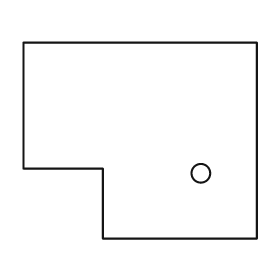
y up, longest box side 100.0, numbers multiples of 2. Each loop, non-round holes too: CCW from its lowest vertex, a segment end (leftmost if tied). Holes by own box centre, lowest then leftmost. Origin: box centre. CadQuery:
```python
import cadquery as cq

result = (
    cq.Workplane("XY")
    .moveTo(-16.0, -42.0)
    .lineTo(50.0, -42.0)
    .lineTo(50.0, 42.0)
    .lineTo(-50.0, 42.0)
    .lineTo(-50.0, -12.0)
    .lineTo(-16.0, -12.0)
    .close()
    .moveTo(26.0, -14.0)
    .circle(4.0)
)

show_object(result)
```